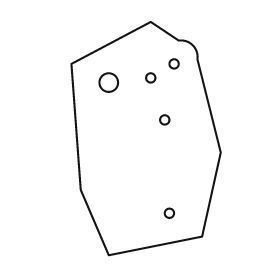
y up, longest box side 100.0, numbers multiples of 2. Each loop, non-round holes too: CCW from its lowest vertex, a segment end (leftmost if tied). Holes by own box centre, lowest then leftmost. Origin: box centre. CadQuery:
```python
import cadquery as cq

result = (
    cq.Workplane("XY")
    .moveTo(-16.0, -50.0)
    .lineTo(24.0, -42.0)
    .lineTo(32.0, -6.0)
    .lineTo(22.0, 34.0)
    .threePointArc((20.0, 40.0), (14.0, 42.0))
    .lineTo(2.0, 50.0)
    .lineTo(-32.0, 32.0)
    .lineTo(-28.0, -22.0)
    .close()
    .moveTo(10.0, -32.0)
    .circle(2.0)
    .moveTo(8.0, 8.0)
    .circle(2.0)
    .moveTo(-16.0, 24.0)
    .circle(4.0)
    .moveTo(2.0, 26.0)
    .circle(2.0)
    .moveTo(12.0, 32.0)
    .circle(2.0)
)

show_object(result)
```